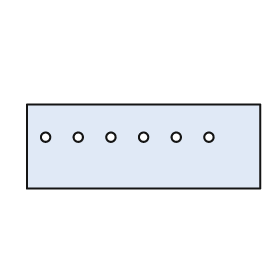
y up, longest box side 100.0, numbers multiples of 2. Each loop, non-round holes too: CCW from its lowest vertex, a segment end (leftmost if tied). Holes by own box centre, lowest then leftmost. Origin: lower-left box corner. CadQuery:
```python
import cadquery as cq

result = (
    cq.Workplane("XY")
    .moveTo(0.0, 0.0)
    .lineTo(100.0, 0.0)
    .lineTo(100.0, 36.0)
    .lineTo(0.0, 36.0)
    .close()
    .moveTo(8.0, 22.0)
    .circle(2.0)
    .moveTo(22.0, 22.0)
    .circle(2.0)
    .moveTo(36.0, 22.0)
    .circle(2.0)
    .moveTo(50.0, 22.0)
    .circle(2.0)
    .moveTo(64.0, 22.0)
    .circle(2.0)
    .moveTo(78.0, 22.0)
    .circle(2.0)
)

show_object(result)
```